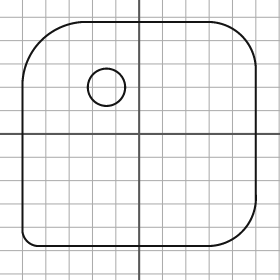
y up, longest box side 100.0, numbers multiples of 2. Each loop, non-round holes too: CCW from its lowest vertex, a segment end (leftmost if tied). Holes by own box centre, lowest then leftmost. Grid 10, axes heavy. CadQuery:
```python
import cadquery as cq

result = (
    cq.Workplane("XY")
    .moveTo(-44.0, -48.0)
    .lineTo(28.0, -48.0)
    .threePointArc((44.0, -42.0), (50.0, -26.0))
    .lineTo(50.0, 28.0)
    .threePointArc((44.0, 42.0), (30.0, 48.0))
    .lineTo(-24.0, 48.0)
    .threePointArc((-42.0, 40.0), (-50.0, 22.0))
    .lineTo(-50.0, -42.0)
    .threePointArc((-48.0, -46.0), (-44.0, -48.0))
    .close()
    .moveTo(-14.0, 20.0)
    .circle(8.0)
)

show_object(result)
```